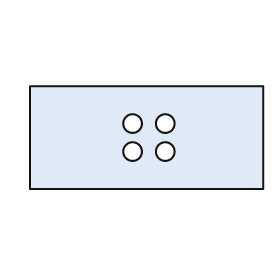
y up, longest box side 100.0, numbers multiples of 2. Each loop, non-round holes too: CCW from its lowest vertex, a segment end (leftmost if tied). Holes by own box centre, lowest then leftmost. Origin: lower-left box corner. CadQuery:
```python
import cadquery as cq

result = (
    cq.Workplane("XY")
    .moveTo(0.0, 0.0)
    .lineTo(100.0, 0.0)
    .lineTo(100.0, 44.0)
    .lineTo(0.0, 44.0)
    .close()
    .moveTo(44.0, 16.0)
    .circle(4.0)
    .moveTo(58.0, 16.0)
    .circle(4.0)
    .moveTo(44.0, 28.0)
    .circle(4.0)
    .moveTo(58.0, 28.0)
    .circle(4.0)
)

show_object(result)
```